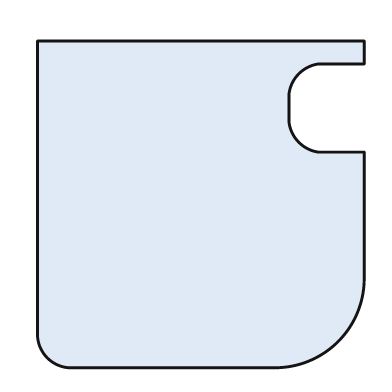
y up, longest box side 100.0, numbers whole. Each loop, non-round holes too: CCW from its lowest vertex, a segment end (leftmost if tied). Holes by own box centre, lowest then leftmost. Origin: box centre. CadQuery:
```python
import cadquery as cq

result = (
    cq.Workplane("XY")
    .moveTo(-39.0, -50.0)
    .lineTo(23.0, -50.0)
    .threePointArc((42.0, -42.0), (50.0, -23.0))
    .lineTo(50.0, 16.0)
    .lineTo(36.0, 16.0)
    .threePointArc((30.0, 19.0), (27.0, 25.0))
    .lineTo(27.0, 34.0)
    .threePointArc((30.0, 40.0), (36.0, 43.0))
    .lineTo(50.0, 43.0)
    .lineTo(50.0, 50.0)
    .lineTo(-50.0, 50.0)
    .lineTo(-50.0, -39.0)
    .threePointArc((-47.0, -47.0), (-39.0, -50.0))
    .close()
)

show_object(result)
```